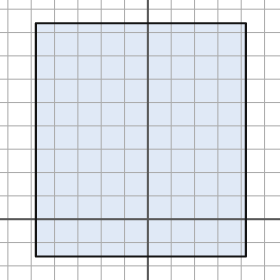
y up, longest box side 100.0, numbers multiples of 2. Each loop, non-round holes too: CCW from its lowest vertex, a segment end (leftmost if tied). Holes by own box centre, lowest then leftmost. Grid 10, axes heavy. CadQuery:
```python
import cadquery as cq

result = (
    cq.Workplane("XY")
    .moveTo(-48.0, -16.0)
    .lineTo(42.0, -16.0)
    .lineTo(42.0, 84.0)
    .lineTo(-48.0, 84.0)
    .close()
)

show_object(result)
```